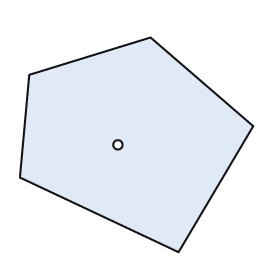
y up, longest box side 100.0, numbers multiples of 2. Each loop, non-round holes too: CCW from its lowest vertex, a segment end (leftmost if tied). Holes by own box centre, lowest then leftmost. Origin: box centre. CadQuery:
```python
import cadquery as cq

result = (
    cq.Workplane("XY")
    .moveTo(18.0, -46.0)
    .lineTo(50.0, 8.0)
    .lineTo(6.0, 46.0)
    .lineTo(-46.0, 30.0)
    .lineTo(-50.0, -14.0)
    .close()
    .moveTo(-8.0, 0.0)
    .circle(2.0)
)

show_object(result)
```